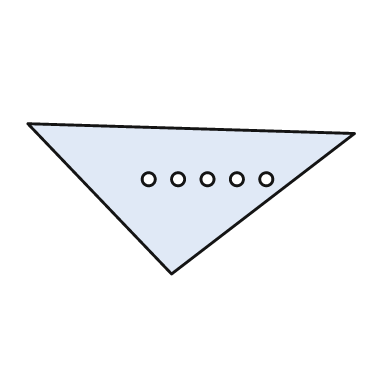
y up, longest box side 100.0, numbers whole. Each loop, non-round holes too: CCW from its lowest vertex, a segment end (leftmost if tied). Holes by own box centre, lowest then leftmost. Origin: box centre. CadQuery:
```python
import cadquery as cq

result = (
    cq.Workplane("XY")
    .moveTo(-6.0, -23.0)
    .lineTo(50.0, 20.0)
    .lineTo(-50.0, 23.0)
    .close()
    .moveTo(-13.0, 6.0)
    .circle(2.0)
    .moveTo(-4.0, 6.0)
    .circle(2.0)
    .moveTo(5.0, 6.0)
    .circle(2.0)
    .moveTo(14.0, 6.0)
    .circle(2.0)
    .moveTo(23.0, 6.0)
    .circle(2.0)
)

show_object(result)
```